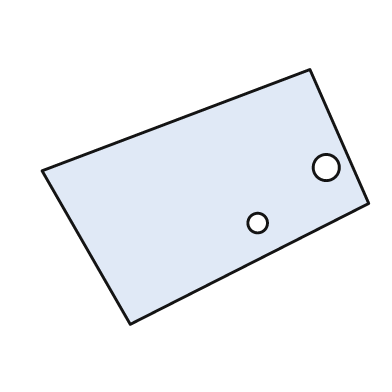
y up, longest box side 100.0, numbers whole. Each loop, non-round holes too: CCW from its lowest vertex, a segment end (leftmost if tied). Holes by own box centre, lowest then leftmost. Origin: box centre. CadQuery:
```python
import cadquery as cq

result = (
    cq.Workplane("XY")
    .moveTo(-23.0, -39.0)
    .lineTo(50.0, -2.0)
    .lineTo(32.0, 39.0)
    .lineTo(-50.0, 8.0)
    .close()
    .moveTo(16.0, -8.0)
    .circle(3.0)
    .moveTo(37.0, 9.0)
    .circle(4.0)
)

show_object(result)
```